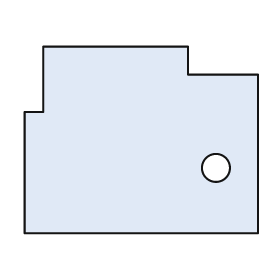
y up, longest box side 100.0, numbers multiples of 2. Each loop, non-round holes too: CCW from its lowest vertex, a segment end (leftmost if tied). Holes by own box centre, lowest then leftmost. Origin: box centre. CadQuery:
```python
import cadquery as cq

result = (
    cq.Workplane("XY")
    .moveTo(-50.0, -40.0)
    .lineTo(50.0, -40.0)
    .lineTo(50.0, 28.0)
    .lineTo(20.0, 28.0)
    .lineTo(20.0, 40.0)
    .lineTo(-42.0, 40.0)
    .lineTo(-42.0, 12.0)
    .lineTo(-50.0, 12.0)
    .close()
    .moveTo(32.0, -12.0)
    .circle(6.0)
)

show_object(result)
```